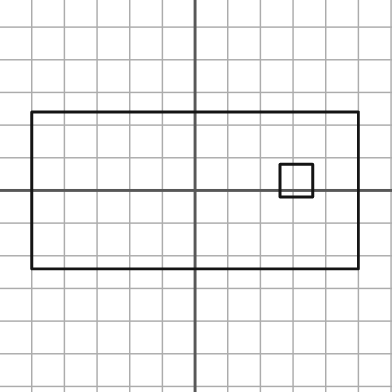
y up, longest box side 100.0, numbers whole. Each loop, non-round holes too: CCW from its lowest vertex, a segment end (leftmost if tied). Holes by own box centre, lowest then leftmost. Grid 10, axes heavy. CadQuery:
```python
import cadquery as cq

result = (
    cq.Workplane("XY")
    .moveTo(-50.0, -24.0)
    .lineTo(50.0, -24.0)
    .lineTo(50.0, 24.0)
    .lineTo(-50.0, 24.0)
    .close()
    .moveTo(26.0, -2.0)
    .lineTo(36.0, -2.0)
    .lineTo(36.0, 8.0)
    .lineTo(26.0, 8.0)
    .close()
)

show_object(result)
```